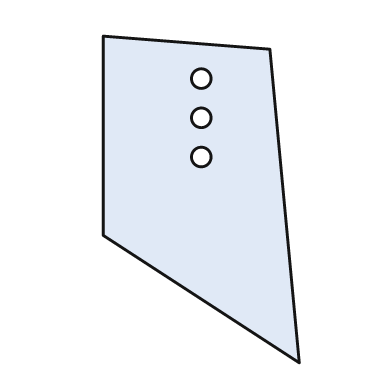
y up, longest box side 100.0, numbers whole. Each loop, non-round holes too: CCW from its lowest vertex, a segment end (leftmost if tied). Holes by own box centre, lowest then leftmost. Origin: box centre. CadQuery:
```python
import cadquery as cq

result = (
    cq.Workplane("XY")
    .moveTo(30.0, -50.0)
    .lineTo(21.0, 46.0)
    .lineTo(-30.0, 50.0)
    .lineTo(-30.0, -11.0)
    .close()
    .moveTo(0.0, 13.0)
    .circle(3.0)
    .moveTo(0.0, 25.0)
    .circle(3.0)
    .moveTo(0.0, 37.0)
    .circle(3.0)
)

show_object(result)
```